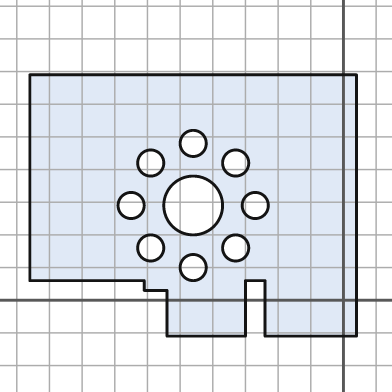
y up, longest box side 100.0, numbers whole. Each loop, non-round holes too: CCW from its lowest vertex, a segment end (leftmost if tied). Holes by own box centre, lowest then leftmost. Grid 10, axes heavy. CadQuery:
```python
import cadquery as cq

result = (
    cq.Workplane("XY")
    .moveTo(-54.0, -11.0)
    .lineTo(-30.0, -11.0)
    .lineTo(-30.0, 6.0)
    .lineTo(-24.0, 6.0)
    .lineTo(-24.0, -11.0)
    .lineTo(4.0, -11.0)
    .lineTo(4.0, 69.0)
    .lineTo(-96.0, 69.0)
    .lineTo(-96.0, 6.0)
    .lineTo(-61.0, 6.0)
    .lineTo(-61.0, 3.0)
    .lineTo(-54.0, 3.0)
    .close()
    .moveTo(-46.0, 10.0)
    .circle(4.0)
    .moveTo(-59.0, 16.0)
    .circle(4.0)
    .moveTo(-33.0, 16.0)
    .circle(4.0)
    .moveTo(-65.0, 29.0)
    .circle(4.0)
    .moveTo(-46.0, 29.0)
    .circle(9.0)
    .moveTo(-27.0, 29.0)
    .circle(4.0)
    .moveTo(-59.0, 42.0)
    .circle(4.0)
    .moveTo(-33.0, 42.0)
    .circle(4.0)
    .moveTo(-46.0, 48.0)
    .circle(4.0)
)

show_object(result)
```